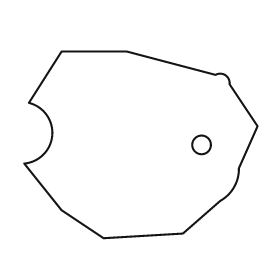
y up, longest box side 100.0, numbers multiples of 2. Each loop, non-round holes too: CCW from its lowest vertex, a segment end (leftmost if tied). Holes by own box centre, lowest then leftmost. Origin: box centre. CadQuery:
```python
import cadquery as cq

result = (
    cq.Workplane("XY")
    .moveTo(-16.0, -40.0)
    .lineTo(18.0, -38.0)
    .lineTo(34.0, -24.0)
    .threePointArc((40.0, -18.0), (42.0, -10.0))
    .lineTo(50.0, 8.0)
    .lineTo(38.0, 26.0)
    .threePointArc((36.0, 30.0), (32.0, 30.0))
    .lineTo(-6.0, 40.0)
    .lineTo(-34.0, 40.0)
    .lineTo(-48.0, 18.0)
    .threePointArc((-38.0, 4.0), (-50.0, -8.0))
    .lineTo(-34.0, -28.0)
    .close()
    .moveTo(26.0, 0.0)
    .circle(4.0)
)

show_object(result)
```